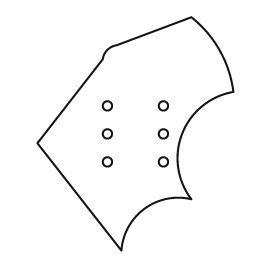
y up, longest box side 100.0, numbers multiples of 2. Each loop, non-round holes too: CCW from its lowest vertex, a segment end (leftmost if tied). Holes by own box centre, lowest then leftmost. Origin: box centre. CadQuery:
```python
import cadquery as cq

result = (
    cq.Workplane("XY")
    .moveTo(-6.0, -50.0)
    .threePointArc((4.0, -32.0), (24.0, -28.0))
    .threePointArc((20.0, 0.0), (42.0, 18.0))
    .threePointArc((36.0, 36.0), (24.0, 50.0))
    .lineTo(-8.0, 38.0)
    .threePointArc((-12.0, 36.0), (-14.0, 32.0))
    .lineTo(-42.0, -4.0)
    .close()
    .moveTo(-12.0, -12.0)
    .circle(2.0)
    .moveTo(12.0, -12.0)
    .circle(2.0)
    .moveTo(-12.0, 0.0)
    .circle(2.0)
    .moveTo(12.0, 0.0)
    .circle(2.0)
    .moveTo(-12.0, 12.0)
    .circle(2.0)
    .moveTo(12.0, 12.0)
    .circle(2.0)
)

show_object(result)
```